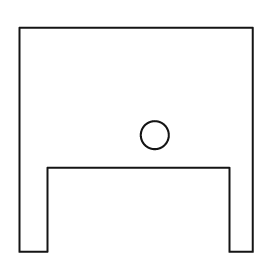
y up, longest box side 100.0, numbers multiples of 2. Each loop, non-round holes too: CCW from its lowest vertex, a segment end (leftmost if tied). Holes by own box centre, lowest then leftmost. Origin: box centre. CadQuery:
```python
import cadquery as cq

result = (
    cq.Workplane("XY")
    .moveTo(-50.0, -48.0)
    .lineTo(-38.0, -48.0)
    .lineTo(-38.0, -12.0)
    .lineTo(40.0, -12.0)
    .lineTo(40.0, -48.0)
    .lineTo(50.0, -48.0)
    .lineTo(50.0, 48.0)
    .lineTo(-50.0, 48.0)
    .close()
    .moveTo(8.0, 2.0)
    .circle(6.0)
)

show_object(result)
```